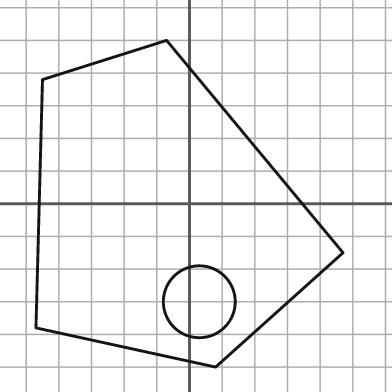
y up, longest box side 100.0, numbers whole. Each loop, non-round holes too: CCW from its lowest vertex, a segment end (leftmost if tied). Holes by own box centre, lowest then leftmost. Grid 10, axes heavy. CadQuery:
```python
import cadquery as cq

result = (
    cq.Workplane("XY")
    .moveTo(8.0, -50.0)
    .lineTo(47.0, -15.0)
    .lineTo(-7.0, 50.0)
    .lineTo(-45.0, 38.0)
    .lineTo(-47.0, -38.0)
    .close()
    .moveTo(3.0, -30.0)
    .circle(11.0)
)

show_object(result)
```